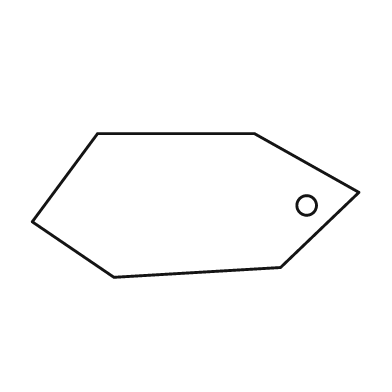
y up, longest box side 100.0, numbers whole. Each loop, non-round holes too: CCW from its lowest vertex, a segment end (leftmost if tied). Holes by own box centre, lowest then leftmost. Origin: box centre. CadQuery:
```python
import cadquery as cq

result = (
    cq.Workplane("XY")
    .moveTo(-25.0, -22.0)
    .lineTo(26.0, -19.0)
    .lineTo(50.0, 4.0)
    .lineTo(18.0, 22.0)
    .lineTo(-30.0, 22.0)
    .lineTo(-50.0, -5.0)
    .close()
    .moveTo(34.0, 0.0)
    .circle(3.0)
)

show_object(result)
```